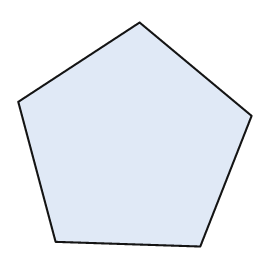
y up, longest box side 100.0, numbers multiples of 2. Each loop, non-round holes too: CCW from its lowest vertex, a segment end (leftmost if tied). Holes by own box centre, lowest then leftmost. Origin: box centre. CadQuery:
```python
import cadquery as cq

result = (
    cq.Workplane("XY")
    .moveTo(28.0, -48.0)
    .lineTo(50.0, 8.0)
    .lineTo(2.0, 48.0)
    .lineTo(-50.0, 14.0)
    .lineTo(-34.0, -46.0)
    .close()
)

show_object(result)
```